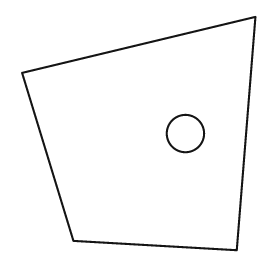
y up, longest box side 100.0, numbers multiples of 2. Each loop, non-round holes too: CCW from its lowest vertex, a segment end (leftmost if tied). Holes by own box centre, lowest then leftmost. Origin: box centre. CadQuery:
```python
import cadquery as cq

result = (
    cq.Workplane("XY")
    .moveTo(42.0, -50.0)
    .lineTo(50.0, 50.0)
    .lineTo(-50.0, 26.0)
    .lineTo(-28.0, -46.0)
    .close()
    .moveTo(20.0, 0.0)
    .circle(8.0)
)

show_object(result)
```